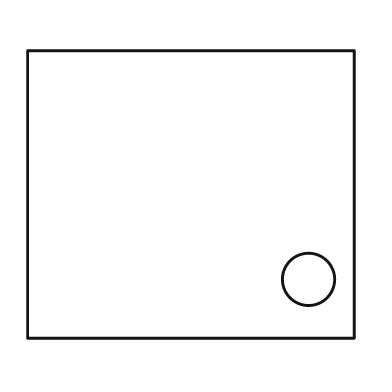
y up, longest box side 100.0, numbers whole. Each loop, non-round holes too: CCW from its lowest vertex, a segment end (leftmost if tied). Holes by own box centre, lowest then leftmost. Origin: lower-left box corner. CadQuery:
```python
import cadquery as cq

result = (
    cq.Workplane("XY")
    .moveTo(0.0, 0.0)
    .lineTo(100.0, 0.0)
    .lineTo(100.0, 88.0)
    .lineTo(0.0, 88.0)
    .close()
    .moveTo(86.0, 18.0)
    .circle(8.0)
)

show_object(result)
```